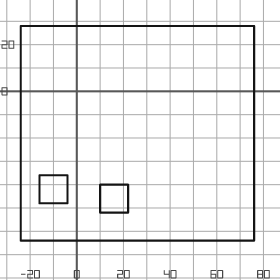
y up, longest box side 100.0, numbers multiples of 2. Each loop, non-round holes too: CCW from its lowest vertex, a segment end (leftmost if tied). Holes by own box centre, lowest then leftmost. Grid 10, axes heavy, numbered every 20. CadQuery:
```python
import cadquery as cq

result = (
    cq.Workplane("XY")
    .moveTo(-24.0, -64.0)
    .lineTo(76.0, -64.0)
    .lineTo(76.0, 28.0)
    .lineTo(-24.0, 28.0)
    .close()
    .moveTo(10.0, -52.0)
    .lineTo(22.0, -52.0)
    .lineTo(22.0, -40.0)
    .lineTo(10.0, -40.0)
    .close()
    .moveTo(-16.0, -48.0)
    .lineTo(-4.0, -48.0)
    .lineTo(-4.0, -36.0)
    .lineTo(-16.0, -36.0)
    .close()
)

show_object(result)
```